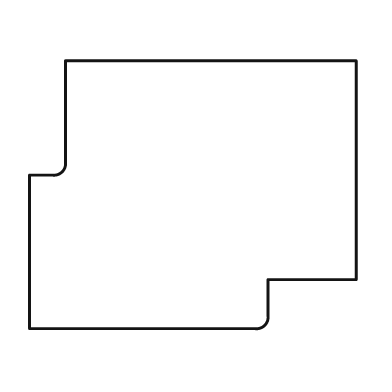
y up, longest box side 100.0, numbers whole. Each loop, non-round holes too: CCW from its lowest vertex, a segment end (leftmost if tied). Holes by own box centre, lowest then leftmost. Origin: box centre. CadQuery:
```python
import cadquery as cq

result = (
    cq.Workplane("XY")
    .moveTo(-50.0, -41.0)
    .lineTo(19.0, -41.0)
    .threePointArc((22.0, -40.0), (23.0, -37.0))
    .lineTo(23.0, -26.0)
    .lineTo(50.0, -26.0)
    .lineTo(50.0, 41.0)
    .lineTo(-39.0, 41.0)
    .lineTo(-39.0, 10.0)
    .threePointArc((-40.0, 7.0), (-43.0, 6.0))
    .lineTo(-50.0, 6.0)
    .close()
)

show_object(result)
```